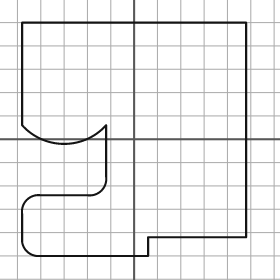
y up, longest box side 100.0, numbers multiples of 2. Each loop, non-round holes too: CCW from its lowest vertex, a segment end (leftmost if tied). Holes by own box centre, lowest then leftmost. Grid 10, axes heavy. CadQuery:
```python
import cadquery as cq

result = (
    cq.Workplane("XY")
    .moveTo(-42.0, -50.0)
    .lineTo(6.0, -50.0)
    .lineTo(6.0, -42.0)
    .lineTo(48.0, -42.0)
    .lineTo(48.0, 50.0)
    .lineTo(-48.0, 50.0)
    .lineTo(-48.0, 6.0)
    .threePointArc((-30.0, -2.0), (-12.0, 6.0))
    .lineTo(-12.0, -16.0)
    .threePointArc((-14.0, -22.0), (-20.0, -24.0))
    .lineTo(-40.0, -24.0)
    .threePointArc((-46.0, -26.0), (-48.0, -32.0))
    .lineTo(-48.0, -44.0)
    .threePointArc((-46.0, -48.0), (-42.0, -50.0))
    .close()
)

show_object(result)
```